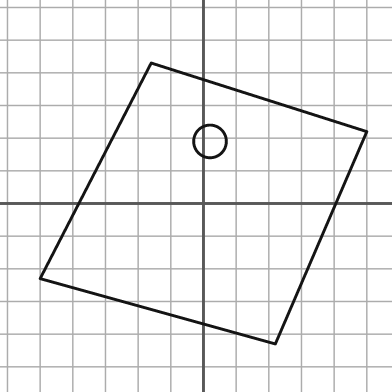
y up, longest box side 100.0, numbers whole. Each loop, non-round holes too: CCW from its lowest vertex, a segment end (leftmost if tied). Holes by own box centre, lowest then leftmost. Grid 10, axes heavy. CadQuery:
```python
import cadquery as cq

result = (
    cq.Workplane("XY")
    .moveTo(22.0, -43.0)
    .lineTo(50.0, 22.0)
    .lineTo(-16.0, 43.0)
    .lineTo(-50.0, -23.0)
    .close()
    .moveTo(2.0, 19.0)
    .circle(5.0)
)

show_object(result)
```